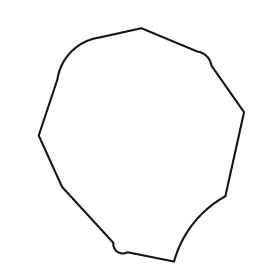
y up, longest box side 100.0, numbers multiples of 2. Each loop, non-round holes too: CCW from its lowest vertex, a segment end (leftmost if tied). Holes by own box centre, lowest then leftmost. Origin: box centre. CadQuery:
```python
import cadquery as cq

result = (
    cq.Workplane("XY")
    .moveTo(14.0, -50.0)
    .threePointArc((22.0, -34.0), (36.0, -22.0))
    .lineTo(44.0, 14.0)
    .lineTo(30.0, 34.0)
    .threePointArc((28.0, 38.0), (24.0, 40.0))
    .lineTo(0.0, 50.0)
    .lineTo(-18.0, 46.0)
    .threePointArc((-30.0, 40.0), (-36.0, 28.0))
    .lineTo(-44.0, 4.0)
    .lineTo(-34.0, -18.0)
    .lineTo(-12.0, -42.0)
    .threePointArc((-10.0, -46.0), (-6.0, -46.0))
    .close()
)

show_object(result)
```